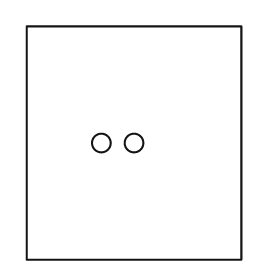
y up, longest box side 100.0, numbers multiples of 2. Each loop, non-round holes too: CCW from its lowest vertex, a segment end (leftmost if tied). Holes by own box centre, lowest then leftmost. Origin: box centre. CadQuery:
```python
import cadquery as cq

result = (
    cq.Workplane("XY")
    .moveTo(-46.0, -50.0)
    .lineTo(46.0, -50.0)
    .lineTo(46.0, 50.0)
    .lineTo(-46.0, 50.0)
    .close()
    .moveTo(-14.0, 0.0)
    .circle(4.0)
    .moveTo(0.0, 0.0)
    .circle(4.0)
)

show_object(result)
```